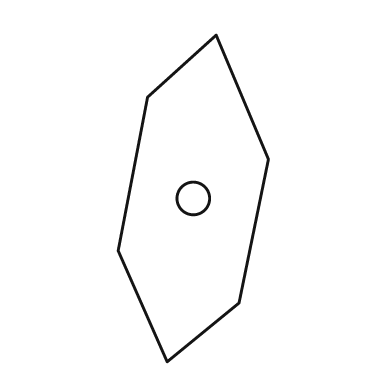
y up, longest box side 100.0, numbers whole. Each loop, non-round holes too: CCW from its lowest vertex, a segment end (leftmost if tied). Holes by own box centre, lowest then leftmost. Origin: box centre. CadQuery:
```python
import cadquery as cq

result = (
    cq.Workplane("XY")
    .moveTo(-8.0, -50.0)
    .lineTo(14.0, -32.0)
    .lineTo(23.0, 12.0)
    .lineTo(7.0, 50.0)
    .lineTo(-14.0, 31.0)
    .lineTo(-23.0, -16.0)
    .close()
    .moveTo(0.0, 0.0)
    .circle(5.0)
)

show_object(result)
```